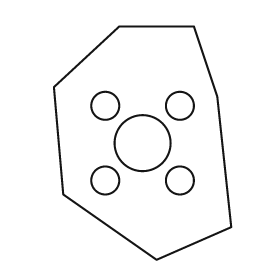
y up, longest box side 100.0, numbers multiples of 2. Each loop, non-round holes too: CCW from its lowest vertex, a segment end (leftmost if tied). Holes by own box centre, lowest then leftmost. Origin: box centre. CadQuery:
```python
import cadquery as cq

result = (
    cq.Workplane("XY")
    .moveTo(6.0, -50.0)
    .lineTo(38.0, -36.0)
    .lineTo(32.0, 20.0)
    .lineTo(22.0, 50.0)
    .lineTo(-10.0, 50.0)
    .lineTo(-38.0, 24.0)
    .lineTo(-34.0, -22.0)
    .close()
    .moveTo(-16.0, -16.0)
    .circle(6.0)
    .moveTo(16.0, -16.0)
    .circle(6.0)
    .moveTo(0.0, 0.0)
    .circle(12.0)
    .moveTo(-16.0, 16.0)
    .circle(6.0)
    .moveTo(16.0, 16.0)
    .circle(6.0)
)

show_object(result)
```